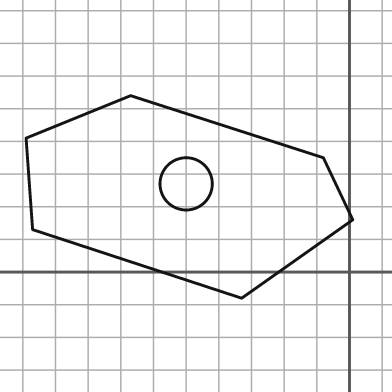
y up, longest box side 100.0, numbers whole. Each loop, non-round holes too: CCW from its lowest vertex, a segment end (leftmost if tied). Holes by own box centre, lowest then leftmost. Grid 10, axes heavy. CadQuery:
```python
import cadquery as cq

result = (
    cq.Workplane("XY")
    .moveTo(-33.0, -8.0)
    .lineTo(1.0, 16.0)
    .lineTo(-8.0, 35.0)
    .lineTo(-67.0, 54.0)
    .lineTo(-99.0, 41.0)
    .lineTo(-97.0, 13.0)
    .close()
    .moveTo(-50.0, 27.0)
    .circle(8.0)
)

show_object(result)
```